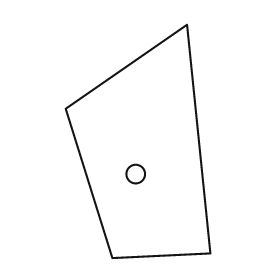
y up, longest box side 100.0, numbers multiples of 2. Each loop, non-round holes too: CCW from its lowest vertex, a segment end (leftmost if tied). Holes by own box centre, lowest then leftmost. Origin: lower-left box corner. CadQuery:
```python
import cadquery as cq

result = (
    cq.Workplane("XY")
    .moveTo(20.0, 0.0)
    .lineTo(62.0, 2.0)
    .lineTo(52.0, 100.0)
    .lineTo(0.0, 64.0)
    .close()
    .moveTo(30.0, 36.0)
    .circle(4.0)
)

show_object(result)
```